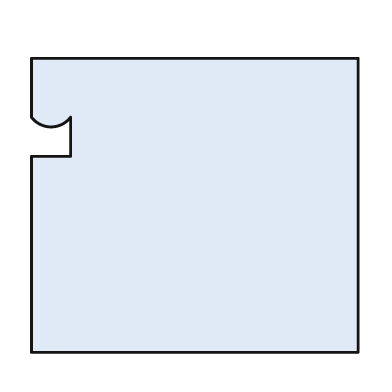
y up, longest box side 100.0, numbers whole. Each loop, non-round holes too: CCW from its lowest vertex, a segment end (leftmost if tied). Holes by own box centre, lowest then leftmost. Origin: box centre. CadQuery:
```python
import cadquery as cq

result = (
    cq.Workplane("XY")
    .moveTo(-50.0, -45.0)
    .lineTo(50.0, -45.0)
    .lineTo(50.0, 45.0)
    .lineTo(-50.0, 45.0)
    .lineTo(-50.0, 27.0)
    .threePointArc((-44.0, 24.0), (-38.0, 27.0))
    .lineTo(-38.0, 15.0)
    .lineTo(-50.0, 15.0)
    .close()
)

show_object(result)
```